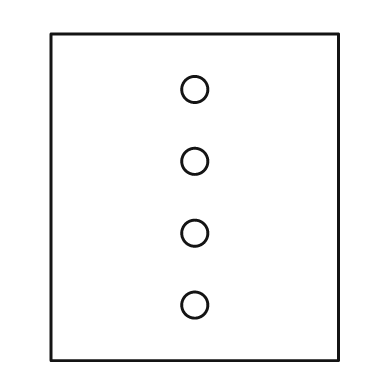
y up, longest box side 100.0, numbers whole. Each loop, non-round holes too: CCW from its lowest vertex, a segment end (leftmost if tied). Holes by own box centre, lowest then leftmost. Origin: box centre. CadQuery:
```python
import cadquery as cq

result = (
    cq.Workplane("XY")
    .moveTo(-44.0, -50.0)
    .lineTo(44.0, -50.0)
    .lineTo(44.0, 50.0)
    .lineTo(-44.0, 50.0)
    .close()
    .moveTo(0.0, -33.0)
    .circle(4.0)
    .moveTo(0.0, -11.0)
    .circle(4.0)
    .moveTo(0.0, 11.0)
    .circle(4.0)
    .moveTo(0.0, 33.0)
    .circle(4.0)
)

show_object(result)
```